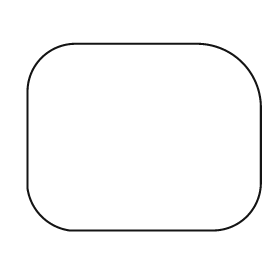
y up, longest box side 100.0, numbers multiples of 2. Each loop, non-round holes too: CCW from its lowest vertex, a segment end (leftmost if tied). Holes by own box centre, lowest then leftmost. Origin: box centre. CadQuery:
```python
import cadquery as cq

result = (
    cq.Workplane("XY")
    .moveTo(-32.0, -40.0)
    .lineTo(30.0, -40.0)
    .threePointArc((44.0, -34.0), (50.0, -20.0))
    .lineTo(50.0, 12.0)
    .threePointArc((42.0, 32.0), (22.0, 40.0))
    .lineTo(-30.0, 40.0)
    .threePointArc((-44.0, 34.0), (-50.0, 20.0))
    .lineTo(-50.0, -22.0)
    .threePointArc((-44.0, -34.0), (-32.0, -40.0))
    .close()
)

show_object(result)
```